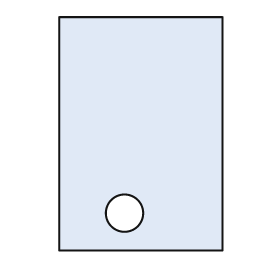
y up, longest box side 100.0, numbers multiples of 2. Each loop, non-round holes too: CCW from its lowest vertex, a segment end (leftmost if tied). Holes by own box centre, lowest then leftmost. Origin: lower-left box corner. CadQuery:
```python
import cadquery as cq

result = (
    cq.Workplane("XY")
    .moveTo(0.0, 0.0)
    .lineTo(70.0, 0.0)
    .lineTo(70.0, 100.0)
    .lineTo(0.0, 100.0)
    .close()
    .moveTo(28.0, 16.0)
    .circle(8.0)
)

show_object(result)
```